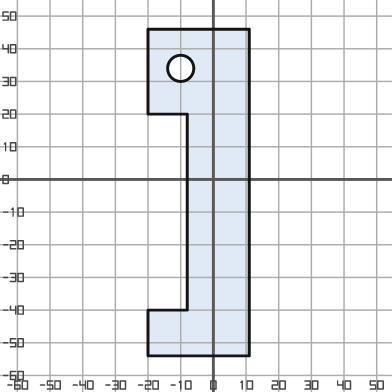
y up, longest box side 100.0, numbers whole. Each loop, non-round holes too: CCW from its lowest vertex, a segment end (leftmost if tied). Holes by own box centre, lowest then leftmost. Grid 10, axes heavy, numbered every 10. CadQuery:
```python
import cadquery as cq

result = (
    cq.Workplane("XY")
    .moveTo(-20.0, -54.0)
    .lineTo(11.0, -54.0)
    .lineTo(11.0, 46.0)
    .lineTo(-20.0, 46.0)
    .lineTo(-20.0, 20.0)
    .lineTo(-8.0, 20.0)
    .lineTo(-8.0, -40.0)
    .lineTo(-20.0, -40.0)
    .close()
    .moveTo(-10.0, 34.0)
    .circle(4.0)
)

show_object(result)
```